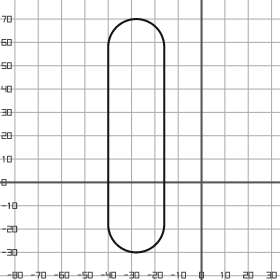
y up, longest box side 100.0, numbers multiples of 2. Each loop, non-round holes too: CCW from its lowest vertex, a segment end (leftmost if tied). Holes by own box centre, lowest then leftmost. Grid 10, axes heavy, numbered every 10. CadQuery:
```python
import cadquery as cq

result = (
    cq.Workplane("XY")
    .moveTo(-40.0, -18.0)
    .threePointArc((-28.0, -30.0), (-16.0, -18.0))
    .lineTo(-16.0, 58.0)
    .threePointArc((-28.0, 70.0), (-40.0, 58.0))
    .close()
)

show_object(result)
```